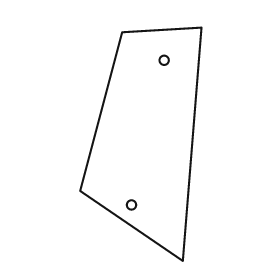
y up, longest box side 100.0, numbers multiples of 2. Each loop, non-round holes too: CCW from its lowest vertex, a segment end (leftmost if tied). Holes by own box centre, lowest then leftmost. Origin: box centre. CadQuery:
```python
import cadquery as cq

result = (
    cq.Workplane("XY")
    .moveTo(18.0, -50.0)
    .lineTo(26.0, 50.0)
    .lineTo(-8.0, 48.0)
    .lineTo(-26.0, -20.0)
    .close()
    .moveTo(-4.0, -26.0)
    .circle(2.0)
    .moveTo(10.0, 36.0)
    .circle(2.0)
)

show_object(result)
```